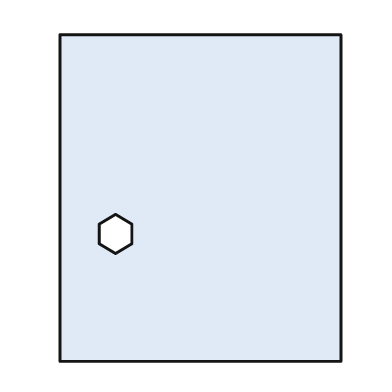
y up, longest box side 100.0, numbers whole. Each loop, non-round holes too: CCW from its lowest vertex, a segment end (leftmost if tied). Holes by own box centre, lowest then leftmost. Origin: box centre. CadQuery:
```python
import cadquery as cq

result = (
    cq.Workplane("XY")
    .moveTo(-43.0, -50.0)
    .lineTo(43.0, -50.0)
    .lineTo(43.0, 50.0)
    .lineTo(-43.0, 50.0)
    .close()
    .moveTo(-26.0, -17.0)
    .lineTo(-21.0, -14.0)
    .lineTo(-21.0, -8.0)
    .lineTo(-26.0, -5.0)
    .lineTo(-31.0, -8.0)
    .lineTo(-31.0, -14.0)
    .close()
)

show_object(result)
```